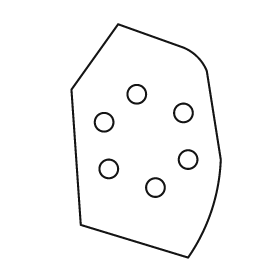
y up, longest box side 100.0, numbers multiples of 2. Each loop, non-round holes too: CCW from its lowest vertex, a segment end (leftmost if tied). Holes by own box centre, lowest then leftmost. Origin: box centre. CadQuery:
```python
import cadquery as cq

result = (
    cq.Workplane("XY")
    .moveTo(18.0, -50.0)
    .threePointArc((28.0, -30.0), (32.0, -8.0))
    .lineTo(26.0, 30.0)
    .threePointArc((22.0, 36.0), (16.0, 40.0))
    .lineTo(-12.0, 50.0)
    .lineTo(-32.0, 22.0)
    .lineTo(-28.0, -36.0)
    .close()
    .moveTo(4.0, -20.0)
    .circle(4.0)
    .moveTo(-16.0, -12.0)
    .circle(4.0)
    .moveTo(18.0, -8.0)
    .circle(4.0)
    .moveTo(-18.0, 8.0)
    .circle(4.0)
    .moveTo(16.0, 12.0)
    .circle(4.0)
    .moveTo(-4.0, 20.0)
    .circle(4.0)
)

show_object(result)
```